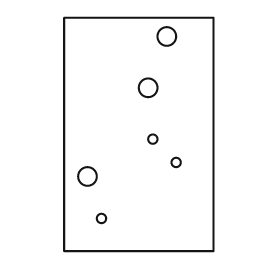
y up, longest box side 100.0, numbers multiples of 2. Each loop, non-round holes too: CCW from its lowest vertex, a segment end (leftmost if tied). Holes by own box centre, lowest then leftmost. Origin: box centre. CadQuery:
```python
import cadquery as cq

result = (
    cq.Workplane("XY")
    .moveTo(-32.0, -50.0)
    .lineTo(32.0, -50.0)
    .lineTo(32.0, 50.0)
    .lineTo(-32.0, 50.0)
    .close()
    .moveTo(-16.0, -36.0)
    .circle(2.0)
    .moveTo(-22.0, -18.0)
    .circle(4.0)
    .moveTo(16.0, -12.0)
    .circle(2.0)
    .moveTo(6.0, -2.0)
    .circle(2.0)
    .moveTo(4.0, 20.0)
    .circle(4.0)
    .moveTo(12.0, 42.0)
    .circle(4.0)
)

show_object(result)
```